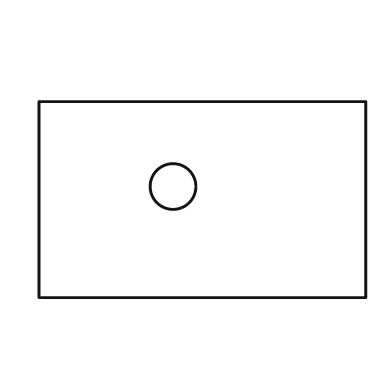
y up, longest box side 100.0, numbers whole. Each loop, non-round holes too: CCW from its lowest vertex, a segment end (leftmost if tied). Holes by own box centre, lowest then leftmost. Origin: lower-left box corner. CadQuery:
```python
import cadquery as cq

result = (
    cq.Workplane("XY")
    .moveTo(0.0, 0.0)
    .lineTo(100.0, 0.0)
    .lineTo(100.0, 60.0)
    .lineTo(0.0, 60.0)
    .close()
    .moveTo(41.0, 34.0)
    .circle(7.0)
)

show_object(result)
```